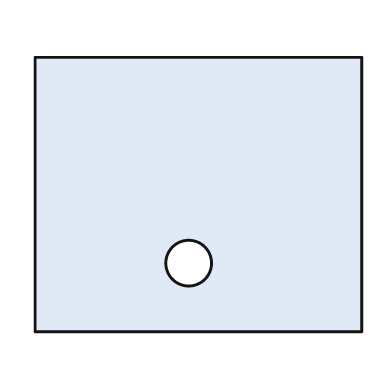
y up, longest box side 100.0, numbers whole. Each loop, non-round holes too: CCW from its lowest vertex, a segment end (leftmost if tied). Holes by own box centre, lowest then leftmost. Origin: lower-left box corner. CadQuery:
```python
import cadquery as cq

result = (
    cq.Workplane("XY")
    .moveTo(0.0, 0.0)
    .lineTo(100.0, 0.0)
    .lineTo(100.0, 84.0)
    .lineTo(0.0, 84.0)
    .close()
    .moveTo(47.0, 21.0)
    .circle(7.0)
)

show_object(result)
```